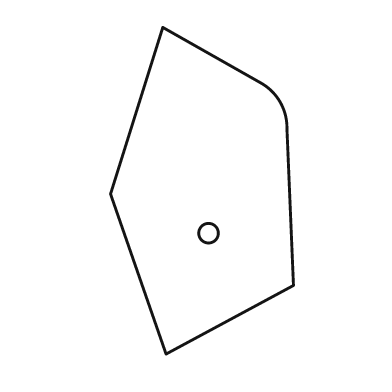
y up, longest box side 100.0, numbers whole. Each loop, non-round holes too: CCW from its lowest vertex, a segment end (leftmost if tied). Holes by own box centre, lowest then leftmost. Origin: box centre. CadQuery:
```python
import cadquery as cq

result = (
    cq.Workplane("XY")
    .moveTo(-11.0, -50.0)
    .lineTo(28.0, -29.0)
    .lineTo(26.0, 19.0)
    .threePointArc((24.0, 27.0), (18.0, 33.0))
    .lineTo(-12.0, 50.0)
    .lineTo(-28.0, -1.0)
    .close()
    .moveTo(2.0, -13.0)
    .circle(3.0)
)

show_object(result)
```